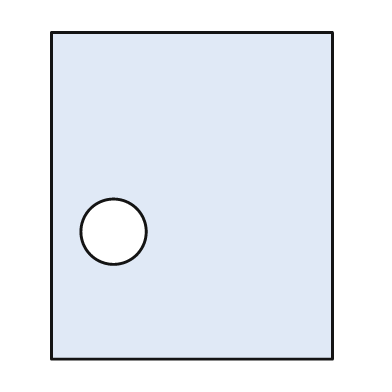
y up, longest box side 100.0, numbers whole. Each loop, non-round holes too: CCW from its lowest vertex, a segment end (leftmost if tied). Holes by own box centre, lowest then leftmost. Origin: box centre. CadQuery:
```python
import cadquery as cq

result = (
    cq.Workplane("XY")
    .moveTo(-43.0, -50.0)
    .lineTo(43.0, -50.0)
    .lineTo(43.0, 50.0)
    .lineTo(-43.0, 50.0)
    .close()
    .moveTo(-24.0, -11.0)
    .circle(10.0)
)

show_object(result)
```